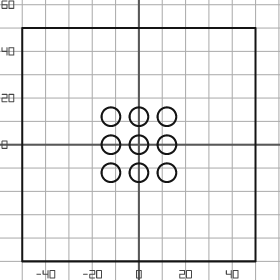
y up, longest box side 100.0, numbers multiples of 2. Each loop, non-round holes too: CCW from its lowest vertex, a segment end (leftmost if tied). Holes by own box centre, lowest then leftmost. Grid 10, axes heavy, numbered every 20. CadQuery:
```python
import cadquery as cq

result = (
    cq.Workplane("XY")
    .moveTo(-50.0, -50.0)
    .lineTo(50.0, -50.0)
    .lineTo(50.0, 50.0)
    .lineTo(-50.0, 50.0)
    .close()
    .moveTo(-12.0, -12.0)
    .circle(4.0)
    .moveTo(0.0, -12.0)
    .circle(4.0)
    .moveTo(12.0, -12.0)
    .circle(4.0)
    .moveTo(-12.0, 0.0)
    .circle(4.0)
    .moveTo(0.0, 0.0)
    .circle(4.0)
    .moveTo(12.0, 0.0)
    .circle(4.0)
    .moveTo(-12.0, 12.0)
    .circle(4.0)
    .moveTo(0.0, 12.0)
    .circle(4.0)
    .moveTo(12.0, 12.0)
    .circle(4.0)
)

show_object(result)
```